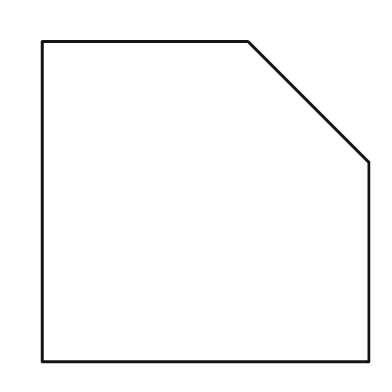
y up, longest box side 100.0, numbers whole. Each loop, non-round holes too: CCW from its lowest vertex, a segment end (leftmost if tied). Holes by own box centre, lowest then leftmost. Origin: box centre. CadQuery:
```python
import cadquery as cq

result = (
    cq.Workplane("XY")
    .moveTo(-50.0, -49.0)
    .lineTo(50.0, -49.0)
    .lineTo(50.0, 12.0)
    .lineTo(13.0, 49.0)
    .lineTo(-50.0, 49.0)
    .close()
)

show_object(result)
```